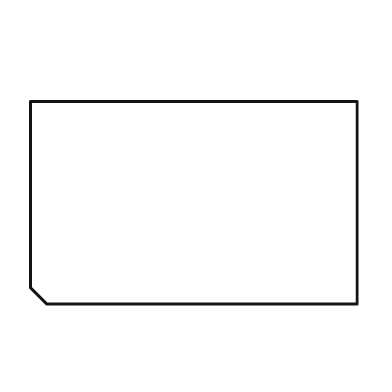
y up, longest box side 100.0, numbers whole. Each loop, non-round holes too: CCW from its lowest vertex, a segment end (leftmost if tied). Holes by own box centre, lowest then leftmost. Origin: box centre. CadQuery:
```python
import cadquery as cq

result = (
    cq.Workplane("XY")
    .moveTo(-45.0, -31.0)
    .lineTo(50.0, -31.0)
    .lineTo(50.0, 31.0)
    .lineTo(-50.0, 31.0)
    .lineTo(-50.0, -26.0)
    .close()
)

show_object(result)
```